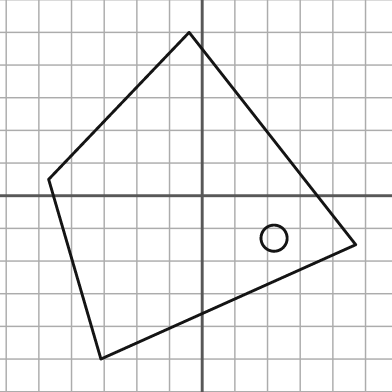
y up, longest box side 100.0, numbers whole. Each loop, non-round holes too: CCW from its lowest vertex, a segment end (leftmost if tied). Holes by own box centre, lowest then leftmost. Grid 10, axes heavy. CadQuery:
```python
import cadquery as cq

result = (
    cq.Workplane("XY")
    .moveTo(-31.0, -50.0)
    .lineTo(47.0, -15.0)
    .lineTo(-4.0, 50.0)
    .lineTo(-47.0, 5.0)
    .close()
    .moveTo(22.0, -13.0)
    .circle(4.0)
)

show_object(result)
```